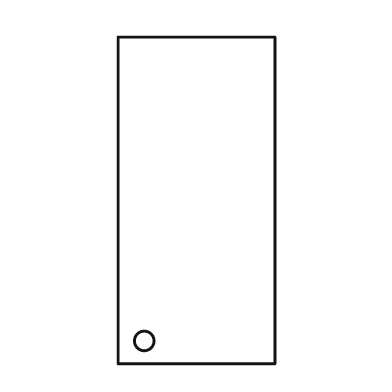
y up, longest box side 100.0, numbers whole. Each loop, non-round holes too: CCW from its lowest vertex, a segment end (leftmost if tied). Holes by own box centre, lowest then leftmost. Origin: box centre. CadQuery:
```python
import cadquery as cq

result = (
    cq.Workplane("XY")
    .moveTo(-24.0, -50.0)
    .lineTo(24.0, -50.0)
    .lineTo(24.0, 50.0)
    .lineTo(-24.0, 50.0)
    .close()
    .moveTo(-16.0, -43.0)
    .circle(3.0)
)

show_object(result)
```